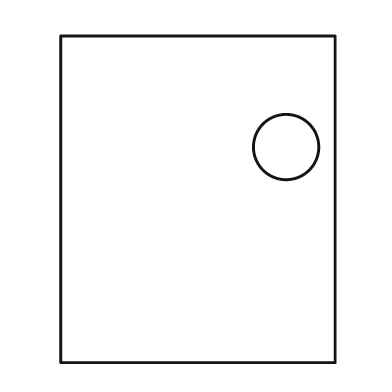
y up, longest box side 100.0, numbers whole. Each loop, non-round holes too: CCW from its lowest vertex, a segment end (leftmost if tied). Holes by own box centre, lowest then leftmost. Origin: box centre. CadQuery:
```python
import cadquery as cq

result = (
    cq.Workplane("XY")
    .moveTo(-42.0, -50.0)
    .lineTo(42.0, -50.0)
    .lineTo(42.0, 50.0)
    .lineTo(-42.0, 50.0)
    .close()
    .moveTo(27.0, 16.0)
    .circle(10.0)
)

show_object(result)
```